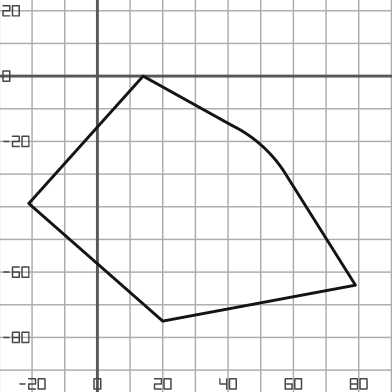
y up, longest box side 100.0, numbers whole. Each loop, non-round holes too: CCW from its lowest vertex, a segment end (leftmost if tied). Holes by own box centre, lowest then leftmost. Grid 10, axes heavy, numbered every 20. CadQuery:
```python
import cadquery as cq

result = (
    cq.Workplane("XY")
    .moveTo(20.0, -75.0)
    .lineTo(79.0, -64.0)
    .lineTo(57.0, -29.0)
    .threePointArc((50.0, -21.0), (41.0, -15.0))
    .lineTo(14.0, 0.0)
    .lineTo(-21.0, -39.0)
    .close()
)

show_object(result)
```